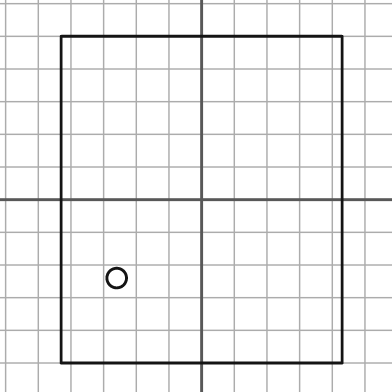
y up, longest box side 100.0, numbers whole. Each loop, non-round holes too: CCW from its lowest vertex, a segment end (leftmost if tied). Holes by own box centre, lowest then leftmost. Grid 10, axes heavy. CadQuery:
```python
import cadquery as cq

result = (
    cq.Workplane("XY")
    .moveTo(-43.0, -50.0)
    .lineTo(43.0, -50.0)
    .lineTo(43.0, 50.0)
    .lineTo(-43.0, 50.0)
    .close()
    .moveTo(-26.0, -24.0)
    .circle(3.0)
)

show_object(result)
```